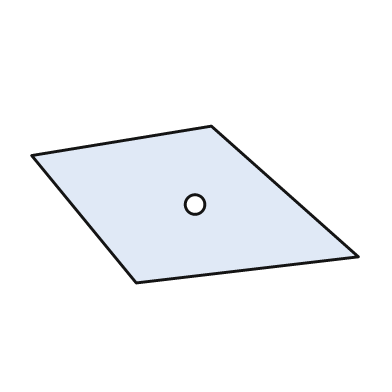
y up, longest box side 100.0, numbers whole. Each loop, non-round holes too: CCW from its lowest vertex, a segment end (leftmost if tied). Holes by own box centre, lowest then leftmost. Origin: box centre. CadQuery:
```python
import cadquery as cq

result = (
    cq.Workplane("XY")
    .moveTo(-18.0, -24.0)
    .lineTo(50.0, -16.0)
    .lineTo(5.0, 24.0)
    .lineTo(-50.0, 15.0)
    .close()
    .moveTo(0.0, 0.0)
    .circle(3.0)
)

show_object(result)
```